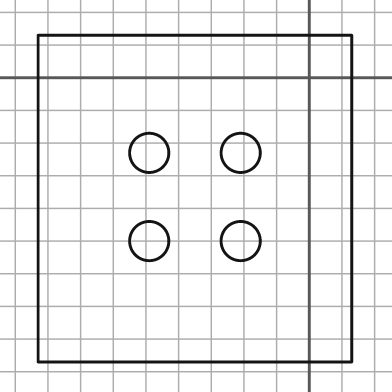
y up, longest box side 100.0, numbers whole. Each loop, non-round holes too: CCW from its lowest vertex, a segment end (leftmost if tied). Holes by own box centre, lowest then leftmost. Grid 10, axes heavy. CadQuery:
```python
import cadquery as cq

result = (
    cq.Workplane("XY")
    .moveTo(-83.0, -87.0)
    .lineTo(13.0, -87.0)
    .lineTo(13.0, 13.0)
    .lineTo(-83.0, 13.0)
    .close()
    .moveTo(-49.0, -50.0)
    .circle(6.0)
    .moveTo(-21.0, -50.0)
    .circle(6.0)
    .moveTo(-49.0, -23.0)
    .circle(6.0)
    .moveTo(-21.0, -23.0)
    .circle(6.0)
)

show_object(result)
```